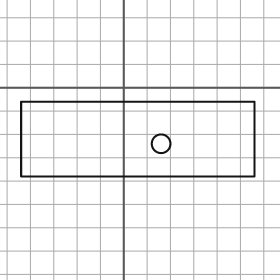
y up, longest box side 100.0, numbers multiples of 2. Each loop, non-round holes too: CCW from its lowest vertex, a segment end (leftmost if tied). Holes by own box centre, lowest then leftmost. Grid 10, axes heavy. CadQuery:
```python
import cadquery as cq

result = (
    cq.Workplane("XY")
    .moveTo(-44.0, -38.0)
    .lineTo(56.0, -38.0)
    .lineTo(56.0, -6.0)
    .lineTo(-44.0, -6.0)
    .close()
    .moveTo(16.0, -24.0)
    .circle(4.0)
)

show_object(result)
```